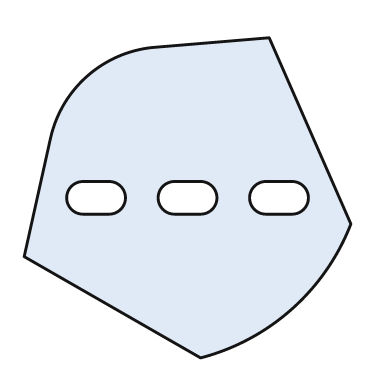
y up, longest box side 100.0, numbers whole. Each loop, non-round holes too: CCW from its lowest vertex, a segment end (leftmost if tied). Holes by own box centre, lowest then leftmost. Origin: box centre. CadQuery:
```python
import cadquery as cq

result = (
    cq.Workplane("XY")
    .moveTo(4.0, -49.0)
    .threePointArc((32.0, -34.0), (50.0, -8.0))
    .lineTo(25.0, 49.0)
    .lineTo(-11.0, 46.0)
    .threePointArc((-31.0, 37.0), (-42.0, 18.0))
    .lineTo(-50.0, -18.0)
    .close()
    .moveTo(-32.0, -5.0)
    .lineTo(-24.0, -5.0)
    .threePointArc((-19.0, 0.0), (-24.0, 5.0))
    .lineTo(-32.0, 5.0)
    .threePointArc((-37.0, 0.0), (-32.0, -5.0))
    .close()
    .moveTo(-4.0, -5.0)
    .lineTo(4.0, -5.0)
    .threePointArc((9.0, 0.0), (4.0, 5.0))
    .lineTo(-4.0, 5.0)
    .threePointArc((-9.0, 0.0), (-4.0, -5.0))
    .close()
    .moveTo(24.0, -5.0)
    .lineTo(32.0, -5.0)
    .threePointArc((37.0, 0.0), (32.0, 5.0))
    .lineTo(24.0, 5.0)
    .threePointArc((19.0, 0.0), (24.0, -5.0))
    .close()
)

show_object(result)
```